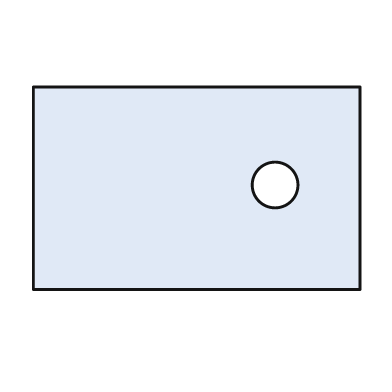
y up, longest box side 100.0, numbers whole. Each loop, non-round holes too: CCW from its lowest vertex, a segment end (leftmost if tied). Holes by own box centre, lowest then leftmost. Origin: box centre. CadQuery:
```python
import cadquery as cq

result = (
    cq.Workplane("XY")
    .moveTo(-50.0, -31.0)
    .lineTo(50.0, -31.0)
    .lineTo(50.0, 31.0)
    .lineTo(-50.0, 31.0)
    .close()
    .moveTo(24.0, 1.0)
    .circle(7.0)
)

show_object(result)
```